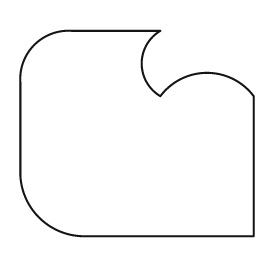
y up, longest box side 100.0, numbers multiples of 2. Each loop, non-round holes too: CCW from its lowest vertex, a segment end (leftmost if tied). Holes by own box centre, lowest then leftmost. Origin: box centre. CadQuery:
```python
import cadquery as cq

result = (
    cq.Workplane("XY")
    .moveTo(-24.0, -44.0)
    .lineTo(50.0, -44.0)
    .lineTo(50.0, 16.0)
    .threePointArc((30.0, 26.0), (10.0, 16.0))
    .threePointArc((2.0, 30.0), (10.0, 44.0))
    .lineTo(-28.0, 44.0)
    .threePointArc((-44.0, 38.0), (-50.0, 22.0))
    .lineTo(-50.0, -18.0)
    .threePointArc((-42.0, -36.0), (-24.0, -44.0))
    .close()
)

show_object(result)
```